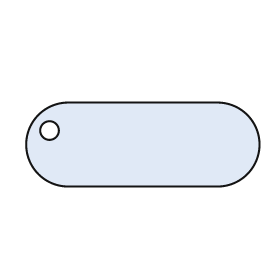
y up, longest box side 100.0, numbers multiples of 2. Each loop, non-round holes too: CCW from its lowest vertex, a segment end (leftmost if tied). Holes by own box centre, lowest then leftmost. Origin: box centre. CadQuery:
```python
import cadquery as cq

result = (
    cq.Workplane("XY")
    .moveTo(-32.0, -18.0)
    .lineTo(32.0, -18.0)
    .threePointArc((50.0, 0.0), (32.0, 18.0))
    .lineTo(-32.0, 18.0)
    .threePointArc((-50.0, 0.0), (-32.0, -18.0))
    .close()
    .moveTo(-40.0, 6.0)
    .circle(4.0)
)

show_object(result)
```